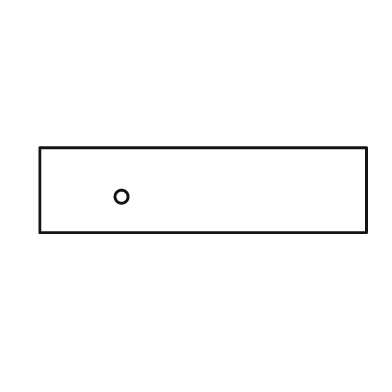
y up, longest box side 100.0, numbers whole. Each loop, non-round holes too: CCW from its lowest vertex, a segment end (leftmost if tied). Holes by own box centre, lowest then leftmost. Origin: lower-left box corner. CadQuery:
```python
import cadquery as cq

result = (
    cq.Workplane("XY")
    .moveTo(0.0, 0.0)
    .lineTo(100.0, 0.0)
    .lineTo(100.0, 26.0)
    .lineTo(0.0, 26.0)
    .close()
    .moveTo(25.0, 11.0)
    .circle(2.0)
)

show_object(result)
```